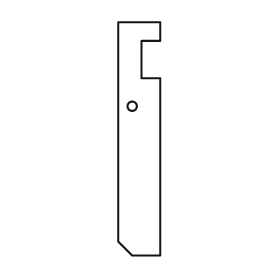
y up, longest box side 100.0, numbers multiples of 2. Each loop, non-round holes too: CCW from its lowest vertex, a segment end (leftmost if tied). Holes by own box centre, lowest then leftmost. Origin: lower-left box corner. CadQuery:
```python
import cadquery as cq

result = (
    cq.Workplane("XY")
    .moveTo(6.0, 0.0)
    .lineTo(18.0, 0.0)
    .lineTo(18.0, 76.0)
    .lineTo(10.0, 76.0)
    .lineTo(10.0, 92.0)
    .lineTo(18.0, 92.0)
    .lineTo(18.0, 100.0)
    .lineTo(0.0, 100.0)
    .lineTo(0.0, 6.0)
    .close()
    .moveTo(6.0, 64.0)
    .circle(2.0)
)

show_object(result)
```